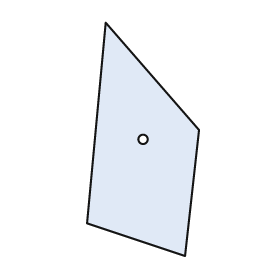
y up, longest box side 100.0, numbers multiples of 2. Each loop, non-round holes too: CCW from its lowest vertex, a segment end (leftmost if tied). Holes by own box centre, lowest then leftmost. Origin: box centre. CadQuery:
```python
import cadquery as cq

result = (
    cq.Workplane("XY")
    .moveTo(18.0, -50.0)
    .lineTo(24.0, 4.0)
    .lineTo(-16.0, 50.0)
    .lineTo(-24.0, -36.0)
    .close()
    .moveTo(0.0, 0.0)
    .circle(2.0)
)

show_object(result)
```